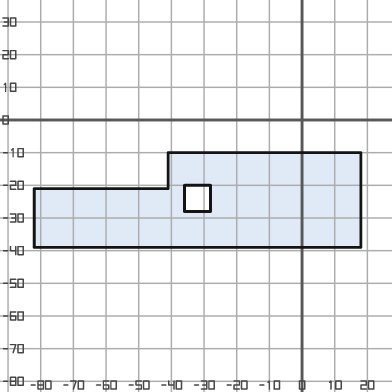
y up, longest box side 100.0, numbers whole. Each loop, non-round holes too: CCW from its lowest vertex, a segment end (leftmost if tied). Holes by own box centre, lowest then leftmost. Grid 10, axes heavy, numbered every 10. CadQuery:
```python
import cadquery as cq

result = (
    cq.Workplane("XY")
    .moveTo(-82.0, -39.0)
    .lineTo(18.0, -39.0)
    .lineTo(18.0, -10.0)
    .lineTo(-41.0, -10.0)
    .lineTo(-41.0, -21.0)
    .lineTo(-82.0, -21.0)
    .close()
    .moveTo(-36.0, -28.0)
    .lineTo(-28.0, -28.0)
    .lineTo(-28.0, -20.0)
    .lineTo(-36.0, -20.0)
    .close()
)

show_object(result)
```